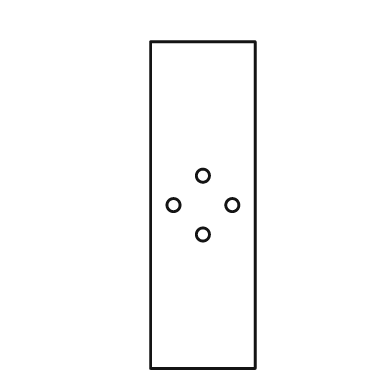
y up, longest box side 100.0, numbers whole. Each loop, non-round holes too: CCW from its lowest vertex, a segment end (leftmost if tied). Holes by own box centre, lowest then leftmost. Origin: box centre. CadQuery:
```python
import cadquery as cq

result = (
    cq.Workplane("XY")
    .moveTo(-16.0, -50.0)
    .lineTo(16.0, -50.0)
    .lineTo(16.0, 50.0)
    .lineTo(-16.0, 50.0)
    .close()
    .moveTo(0.0, -9.0)
    .circle(2.0)
    .moveTo(-9.0, 0.0)
    .circle(2.0)
    .moveTo(9.0, 0.0)
    .circle(2.0)
    .moveTo(0.0, 9.0)
    .circle(2.0)
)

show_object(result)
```